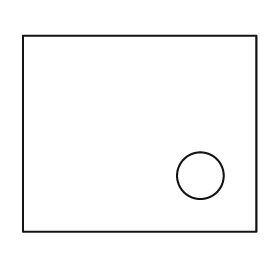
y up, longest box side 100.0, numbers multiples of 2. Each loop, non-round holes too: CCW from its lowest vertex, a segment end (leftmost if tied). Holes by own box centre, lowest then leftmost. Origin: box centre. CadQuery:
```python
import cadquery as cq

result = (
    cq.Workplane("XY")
    .moveTo(-50.0, -42.0)
    .lineTo(50.0, -42.0)
    .lineTo(50.0, 42.0)
    .lineTo(-50.0, 42.0)
    .close()
    .moveTo(26.0, -18.0)
    .circle(10.0)
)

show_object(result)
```